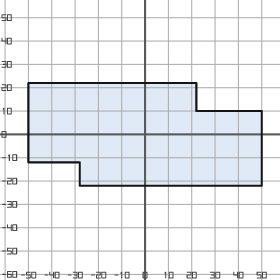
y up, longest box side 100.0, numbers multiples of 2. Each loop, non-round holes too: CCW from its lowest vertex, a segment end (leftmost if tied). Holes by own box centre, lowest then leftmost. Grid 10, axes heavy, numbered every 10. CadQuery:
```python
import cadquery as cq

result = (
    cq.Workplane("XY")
    .moveTo(-28.0, -22.0)
    .lineTo(50.0, -22.0)
    .lineTo(50.0, 10.0)
    .lineTo(22.0, 10.0)
    .lineTo(22.0, 22.0)
    .lineTo(-50.0, 22.0)
    .lineTo(-50.0, -12.0)
    .lineTo(-28.0, -12.0)
    .close()
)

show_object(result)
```